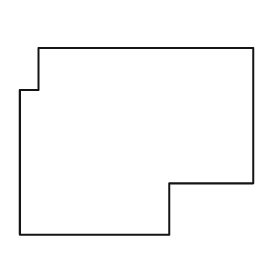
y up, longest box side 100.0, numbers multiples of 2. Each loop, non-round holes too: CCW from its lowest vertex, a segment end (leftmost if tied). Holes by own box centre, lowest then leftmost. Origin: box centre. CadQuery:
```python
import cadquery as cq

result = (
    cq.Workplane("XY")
    .moveTo(-50.0, -40.0)
    .lineTo(14.0, -40.0)
    .lineTo(14.0, -18.0)
    .lineTo(50.0, -18.0)
    .lineTo(50.0, 40.0)
    .lineTo(-42.0, 40.0)
    .lineTo(-42.0, 22.0)
    .lineTo(-50.0, 22.0)
    .close()
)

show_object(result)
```